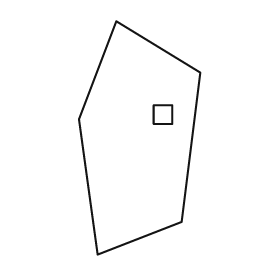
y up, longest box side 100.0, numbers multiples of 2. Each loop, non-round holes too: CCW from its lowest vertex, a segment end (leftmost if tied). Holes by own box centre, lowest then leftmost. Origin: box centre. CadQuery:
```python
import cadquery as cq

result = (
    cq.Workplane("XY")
    .moveTo(-18.0, -50.0)
    .lineTo(18.0, -36.0)
    .lineTo(26.0, 28.0)
    .lineTo(-10.0, 50.0)
    .lineTo(-26.0, 8.0)
    .close()
    .moveTo(6.0, 6.0)
    .lineTo(14.0, 6.0)
    .lineTo(14.0, 14.0)
    .lineTo(6.0, 14.0)
    .close()
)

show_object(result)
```